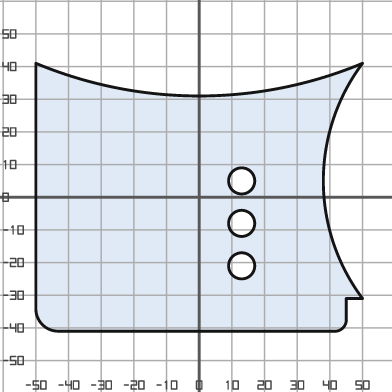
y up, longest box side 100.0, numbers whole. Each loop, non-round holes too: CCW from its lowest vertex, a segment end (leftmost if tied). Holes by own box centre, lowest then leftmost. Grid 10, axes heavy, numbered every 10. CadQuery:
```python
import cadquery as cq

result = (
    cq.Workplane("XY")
    .moveTo(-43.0, -41.0)
    .lineTo(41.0, -41.0)
    .threePointArc((44.0, -40.0), (45.0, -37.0))
    .lineTo(45.0, -31.0)
    .lineTo(50.0, -31.0)
    .threePointArc((38.0, 5.0), (50.0, 41.0))
    .threePointArc((0.0, 31.0), (-50.0, 41.0))
    .lineTo(-50.0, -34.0)
    .threePointArc((-48.0, -39.0), (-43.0, -41.0))
    .close()
    .moveTo(13.0, -21.0)
    .circle(4.0)
    .moveTo(13.0, -8.0)
    .circle(4.0)
    .moveTo(13.0, 5.0)
    .circle(4.0)
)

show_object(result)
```